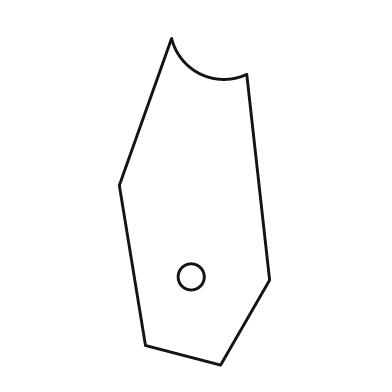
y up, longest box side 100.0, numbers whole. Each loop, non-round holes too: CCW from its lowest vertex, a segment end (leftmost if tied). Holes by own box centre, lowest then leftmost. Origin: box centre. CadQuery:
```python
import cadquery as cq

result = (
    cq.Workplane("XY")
    .moveTo(8.0, -50.0)
    .lineTo(23.0, -24.0)
    .lineTo(16.0, 39.0)
    .threePointArc((2.0, 39.0), (-7.0, 50.0))
    .lineTo(-23.0, 5.0)
    .lineTo(-15.0, -44.0)
    .close()
    .moveTo(-1.0, -23.0)
    .circle(4.0)
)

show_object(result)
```